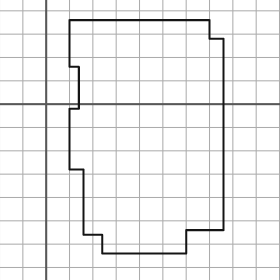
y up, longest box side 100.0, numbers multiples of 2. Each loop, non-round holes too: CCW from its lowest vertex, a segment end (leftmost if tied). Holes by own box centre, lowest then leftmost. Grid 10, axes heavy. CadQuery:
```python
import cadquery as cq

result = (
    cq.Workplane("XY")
    .moveTo(24.0, -64.0)
    .lineTo(60.0, -64.0)
    .lineTo(60.0, -54.0)
    .lineTo(76.0, -54.0)
    .lineTo(76.0, 28.0)
    .lineTo(70.0, 28.0)
    .lineTo(70.0, 36.0)
    .lineTo(10.0, 36.0)
    .lineTo(10.0, 16.0)
    .lineTo(14.0, 16.0)
    .lineTo(14.0, -2.0)
    .lineTo(10.0, -2.0)
    .lineTo(10.0, -28.0)
    .lineTo(16.0, -28.0)
    .lineTo(16.0, -56.0)
    .lineTo(24.0, -56.0)
    .close()
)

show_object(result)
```